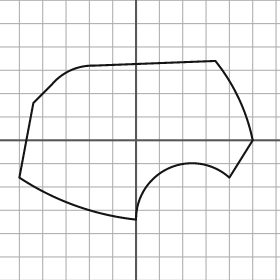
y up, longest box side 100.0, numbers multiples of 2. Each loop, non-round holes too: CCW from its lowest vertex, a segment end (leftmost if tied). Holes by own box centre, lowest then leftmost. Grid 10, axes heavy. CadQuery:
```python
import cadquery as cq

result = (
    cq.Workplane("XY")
    .moveTo(0.0, -34.0)
    .threePointArc((14.0, -12.0), (40.0, -16.0))
    .lineTo(50.0, 0.0)
    .threePointArc((44.0, 18.0), (34.0, 34.0))
    .lineTo(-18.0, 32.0)
    .threePointArc((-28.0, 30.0), (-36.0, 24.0))
    .lineTo(-44.0, 16.0)
    .lineTo(-50.0, -16.0)
    .threePointArc((-26.0, -28.0), (0.0, -34.0))
    .close()
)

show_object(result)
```